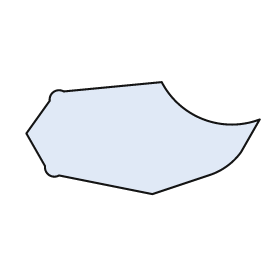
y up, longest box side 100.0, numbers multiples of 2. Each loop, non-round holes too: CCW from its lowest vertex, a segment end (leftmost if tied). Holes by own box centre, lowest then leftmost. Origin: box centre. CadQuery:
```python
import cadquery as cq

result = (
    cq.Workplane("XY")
    .moveTo(4.0, -24.0)
    .lineTo(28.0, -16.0)
    .threePointArc((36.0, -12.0), (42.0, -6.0))
    .lineTo(50.0, 8.0)
    .threePointArc((26.0, 8.0), (8.0, 24.0))
    .lineTo(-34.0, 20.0)
    .threePointArc((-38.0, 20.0), (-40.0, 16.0))
    .lineTo(-50.0, 2.0)
    .lineTo(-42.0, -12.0)
    .threePointArc((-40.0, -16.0), (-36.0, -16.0))
    .close()
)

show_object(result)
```